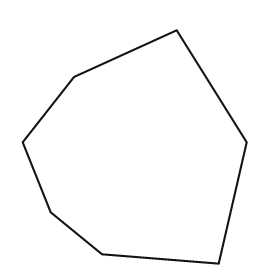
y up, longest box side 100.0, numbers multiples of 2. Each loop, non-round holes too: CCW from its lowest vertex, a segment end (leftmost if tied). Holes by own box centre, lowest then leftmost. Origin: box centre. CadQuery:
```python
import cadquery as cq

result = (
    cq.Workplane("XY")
    .moveTo(36.0, -50.0)
    .lineTo(48.0, 2.0)
    .lineTo(18.0, 50.0)
    .lineTo(-26.0, 30.0)
    .lineTo(-48.0, 2.0)
    .lineTo(-36.0, -28.0)
    .lineTo(-14.0, -46.0)
    .close()
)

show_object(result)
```